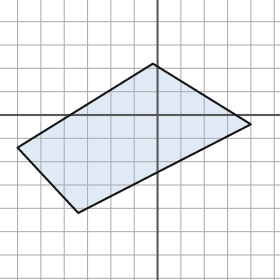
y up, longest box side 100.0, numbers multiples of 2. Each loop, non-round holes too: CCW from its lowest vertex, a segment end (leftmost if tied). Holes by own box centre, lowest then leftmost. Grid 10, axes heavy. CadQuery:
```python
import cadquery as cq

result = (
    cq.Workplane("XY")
    .moveTo(-34.0, -42.0)
    .lineTo(40.0, -4.0)
    .lineTo(-2.0, 22.0)
    .lineTo(-60.0, -14.0)
    .close()
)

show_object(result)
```